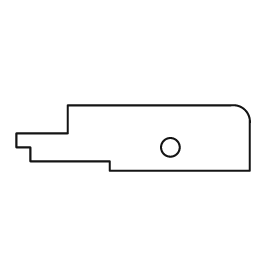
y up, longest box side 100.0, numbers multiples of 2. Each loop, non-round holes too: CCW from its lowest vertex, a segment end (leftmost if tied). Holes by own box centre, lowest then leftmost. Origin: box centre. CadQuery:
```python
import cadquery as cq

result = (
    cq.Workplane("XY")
    .moveTo(-10.0, -14.0)
    .lineTo(50.0, -14.0)
    .lineTo(50.0, 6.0)
    .threePointArc((48.0, 12.0), (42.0, 14.0))
    .lineTo(-28.0, 14.0)
    .lineTo(-28.0, 2.0)
    .lineTo(-50.0, 2.0)
    .lineTo(-50.0, -4.0)
    .lineTo(-44.0, -4.0)
    .lineTo(-44.0, -10.0)
    .lineTo(-10.0, -10.0)
    .close()
    .moveTo(16.0, -4.0)
    .circle(4.0)
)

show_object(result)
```